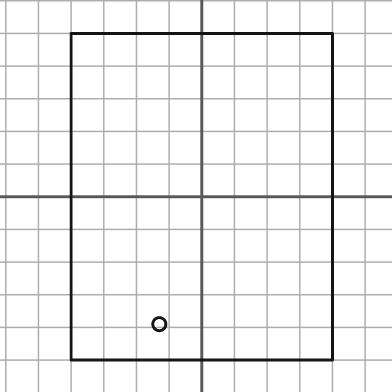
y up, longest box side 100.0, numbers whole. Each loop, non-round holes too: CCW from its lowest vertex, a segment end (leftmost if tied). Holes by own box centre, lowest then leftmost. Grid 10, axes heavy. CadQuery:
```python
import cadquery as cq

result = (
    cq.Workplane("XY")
    .moveTo(-40.0, -50.0)
    .lineTo(40.0, -50.0)
    .lineTo(40.0, 50.0)
    .lineTo(-40.0, 50.0)
    .close()
    .moveTo(-13.0, -39.0)
    .circle(2.0)
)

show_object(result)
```